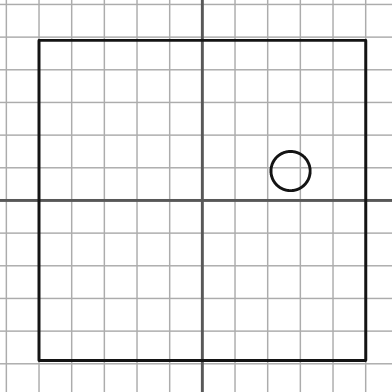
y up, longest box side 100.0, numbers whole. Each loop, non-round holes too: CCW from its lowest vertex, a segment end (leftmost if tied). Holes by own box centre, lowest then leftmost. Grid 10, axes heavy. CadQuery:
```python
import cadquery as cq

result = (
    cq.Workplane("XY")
    .moveTo(-50.0, -49.0)
    .lineTo(50.0, -49.0)
    .lineTo(50.0, 49.0)
    .lineTo(-50.0, 49.0)
    .close()
    .moveTo(27.0, 9.0)
    .circle(6.0)
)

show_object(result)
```